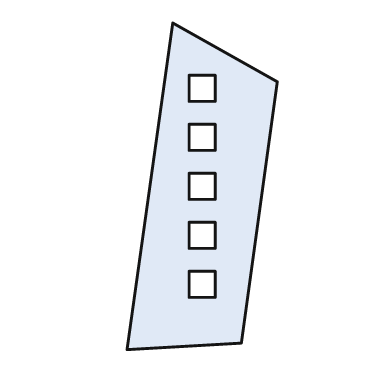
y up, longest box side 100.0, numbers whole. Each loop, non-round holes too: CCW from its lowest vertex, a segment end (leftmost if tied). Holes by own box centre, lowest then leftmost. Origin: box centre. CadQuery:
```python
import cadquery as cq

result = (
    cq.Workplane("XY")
    .moveTo(-23.0, -50.0)
    .lineTo(12.0, -48.0)
    .lineTo(23.0, 32.0)
    .lineTo(-9.0, 50.0)
    .close()
    .moveTo(-4.0, -34.0)
    .lineTo(4.0, -34.0)
    .lineTo(4.0, -26.0)
    .lineTo(-4.0, -26.0)
    .close()
    .moveTo(-4.0, -19.0)
    .lineTo(4.0, -19.0)
    .lineTo(4.0, -11.0)
    .lineTo(-4.0, -11.0)
    .close()
    .moveTo(-4.0, -4.0)
    .lineTo(4.0, -4.0)
    .lineTo(4.0, 4.0)
    .lineTo(-4.0, 4.0)
    .close()
    .moveTo(-4.0, 11.0)
    .lineTo(4.0, 11.0)
    .lineTo(4.0, 19.0)
    .lineTo(-4.0, 19.0)
    .close()
    .moveTo(-4.0, 26.0)
    .lineTo(4.0, 26.0)
    .lineTo(4.0, 34.0)
    .lineTo(-4.0, 34.0)
    .close()
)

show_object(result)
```